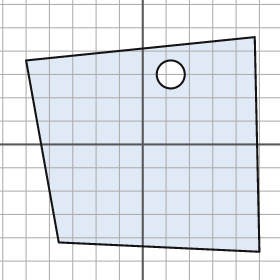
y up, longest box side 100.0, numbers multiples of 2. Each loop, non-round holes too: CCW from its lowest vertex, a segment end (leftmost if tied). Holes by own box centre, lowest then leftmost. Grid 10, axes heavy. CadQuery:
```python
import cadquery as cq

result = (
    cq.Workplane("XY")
    .moveTo(50.0, -46.0)
    .lineTo(48.0, 46.0)
    .lineTo(-50.0, 36.0)
    .lineTo(-36.0, -42.0)
    .close()
    .moveTo(12.0, 30.0)
    .circle(6.0)
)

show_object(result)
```